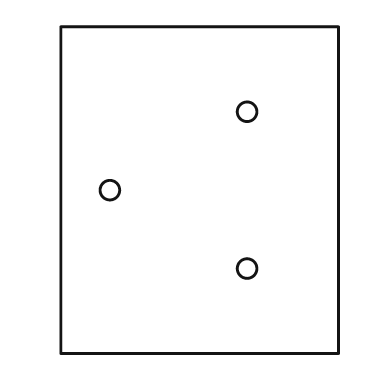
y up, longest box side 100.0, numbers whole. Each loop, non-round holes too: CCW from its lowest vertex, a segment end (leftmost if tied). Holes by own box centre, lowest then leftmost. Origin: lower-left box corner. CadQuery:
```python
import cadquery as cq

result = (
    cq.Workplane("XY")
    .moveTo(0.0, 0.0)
    .lineTo(85.0, 0.0)
    .lineTo(85.0, 100.0)
    .lineTo(0.0, 100.0)
    .close()
    .moveTo(57.0, 26.0)
    .circle(3.0)
    .moveTo(15.0, 50.0)
    .circle(3.0)
    .moveTo(57.0, 74.0)
    .circle(3.0)
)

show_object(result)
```